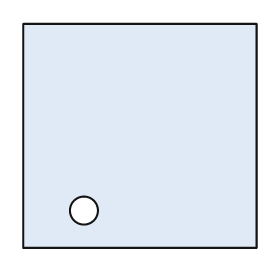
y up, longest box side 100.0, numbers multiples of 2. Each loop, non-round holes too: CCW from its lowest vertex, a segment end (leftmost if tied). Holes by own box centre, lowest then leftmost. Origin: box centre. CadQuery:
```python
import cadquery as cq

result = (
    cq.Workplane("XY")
    .moveTo(-50.0, -48.0)
    .lineTo(50.0, -48.0)
    .lineTo(50.0, 48.0)
    .lineTo(-50.0, 48.0)
    .close()
    .moveTo(-24.0, -32.0)
    .circle(6.0)
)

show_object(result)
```